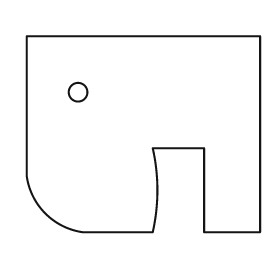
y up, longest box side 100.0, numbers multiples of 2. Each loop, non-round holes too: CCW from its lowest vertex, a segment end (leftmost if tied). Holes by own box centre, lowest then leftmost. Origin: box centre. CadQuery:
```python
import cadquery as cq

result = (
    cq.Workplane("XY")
    .moveTo(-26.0, -42.0)
    .lineTo(4.0, -42.0)
    .threePointArc((6.0, -24.0), (4.0, -6.0))
    .lineTo(26.0, -6.0)
    .lineTo(26.0, -42.0)
    .lineTo(50.0, -42.0)
    .lineTo(50.0, 42.0)
    .lineTo(-50.0, 42.0)
    .lineTo(-50.0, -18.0)
    .threePointArc((-42.0, -34.0), (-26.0, -42.0))
    .close()
    .moveTo(-28.0, 18.0)
    .circle(4.0)
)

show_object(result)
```